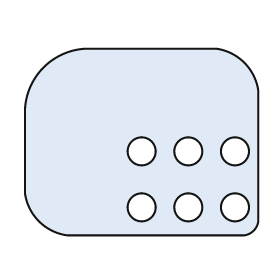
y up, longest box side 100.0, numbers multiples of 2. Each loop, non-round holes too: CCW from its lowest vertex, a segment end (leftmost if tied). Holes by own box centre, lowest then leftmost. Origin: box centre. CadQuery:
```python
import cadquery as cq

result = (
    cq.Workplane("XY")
    .moveTo(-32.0, -40.0)
    .lineTo(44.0, -40.0)
    .threePointArc((48.0, -38.0), (50.0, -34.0))
    .lineTo(50.0, 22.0)
    .threePointArc((44.0, 34.0), (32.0, 40.0))
    .lineTo(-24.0, 40.0)
    .threePointArc((-42.0, 32.0), (-50.0, 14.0))
    .lineTo(-50.0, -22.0)
    .threePointArc((-44.0, -34.0), (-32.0, -40.0))
    .close()
    .moveTo(0.0, -28.0)
    .circle(6.0)
    .moveTo(20.0, -28.0)
    .circle(6.0)
    .moveTo(40.0, -28.0)
    .circle(6.0)
    .moveTo(0.0, -4.0)
    .circle(6.0)
    .moveTo(20.0, -4.0)
    .circle(6.0)
    .moveTo(40.0, -4.0)
    .circle(6.0)
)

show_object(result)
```